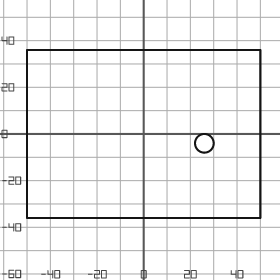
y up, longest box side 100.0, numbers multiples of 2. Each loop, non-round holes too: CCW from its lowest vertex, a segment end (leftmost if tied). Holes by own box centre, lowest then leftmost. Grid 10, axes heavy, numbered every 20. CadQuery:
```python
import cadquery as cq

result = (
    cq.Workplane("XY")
    .moveTo(-50.0, -36.0)
    .lineTo(50.0, -36.0)
    .lineTo(50.0, 36.0)
    .lineTo(-50.0, 36.0)
    .close()
    .moveTo(26.0, -4.0)
    .circle(4.0)
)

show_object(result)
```